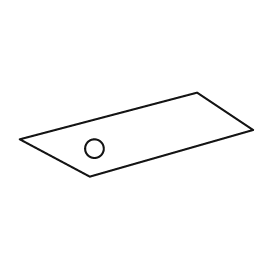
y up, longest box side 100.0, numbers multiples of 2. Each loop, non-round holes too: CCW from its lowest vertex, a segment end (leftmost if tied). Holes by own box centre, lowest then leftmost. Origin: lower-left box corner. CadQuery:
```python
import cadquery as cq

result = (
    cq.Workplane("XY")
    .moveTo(30.0, 0.0)
    .lineTo(100.0, 20.0)
    .lineTo(76.0, 36.0)
    .lineTo(0.0, 16.0)
    .close()
    .moveTo(32.0, 12.0)
    .circle(4.0)
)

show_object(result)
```